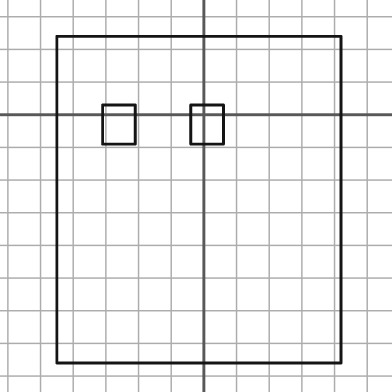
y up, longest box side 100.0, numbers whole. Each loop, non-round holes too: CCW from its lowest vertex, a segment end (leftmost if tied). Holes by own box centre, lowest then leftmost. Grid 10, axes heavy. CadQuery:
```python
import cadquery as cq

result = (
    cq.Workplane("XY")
    .moveTo(-45.0, -76.0)
    .lineTo(42.0, -76.0)
    .lineTo(42.0, 24.0)
    .lineTo(-45.0, 24.0)
    .close()
    .moveTo(-31.0, -9.0)
    .lineTo(-21.0, -9.0)
    .lineTo(-21.0, 3.0)
    .lineTo(-31.0, 3.0)
    .close()
    .moveTo(-4.0, -9.0)
    .lineTo(6.0, -9.0)
    .lineTo(6.0, 3.0)
    .lineTo(-4.0, 3.0)
    .close()
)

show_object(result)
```